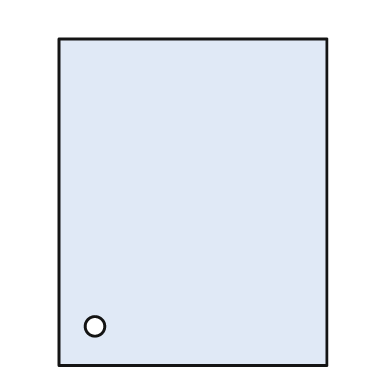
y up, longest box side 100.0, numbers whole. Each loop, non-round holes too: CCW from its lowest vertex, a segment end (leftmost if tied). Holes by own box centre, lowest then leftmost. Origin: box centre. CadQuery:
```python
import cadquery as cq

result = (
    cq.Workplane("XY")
    .moveTo(-41.0, -50.0)
    .lineTo(41.0, -50.0)
    .lineTo(41.0, 50.0)
    .lineTo(-41.0, 50.0)
    .close()
    .moveTo(-30.0, -38.0)
    .circle(3.0)
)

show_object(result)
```